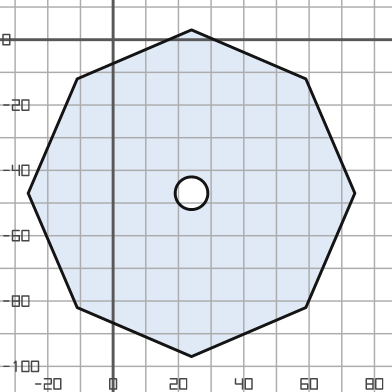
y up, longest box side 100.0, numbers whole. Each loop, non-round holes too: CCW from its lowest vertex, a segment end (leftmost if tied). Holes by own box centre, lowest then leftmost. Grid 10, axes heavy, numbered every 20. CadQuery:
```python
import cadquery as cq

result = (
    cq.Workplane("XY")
    .moveTo(24.0, -97.0)
    .lineTo(59.0, -82.0)
    .lineTo(74.0, -47.0)
    .lineTo(59.0, -12.0)
    .lineTo(24.0, 3.0)
    .lineTo(-11.0, -12.0)
    .lineTo(-26.0, -47.0)
    .lineTo(-11.0, -82.0)
    .close()
    .moveTo(24.0, -47.0)
    .circle(5.0)
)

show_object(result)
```